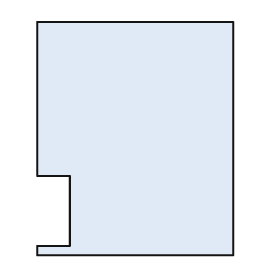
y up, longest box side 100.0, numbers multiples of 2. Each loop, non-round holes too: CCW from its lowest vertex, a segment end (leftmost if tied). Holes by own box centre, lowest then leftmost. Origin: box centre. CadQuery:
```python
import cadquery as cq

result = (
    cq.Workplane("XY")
    .moveTo(-42.0, -50.0)
    .lineTo(42.0, -50.0)
    .lineTo(42.0, 50.0)
    .lineTo(-42.0, 50.0)
    .lineTo(-42.0, -16.0)
    .lineTo(-28.0, -16.0)
    .lineTo(-28.0, -46.0)
    .lineTo(-42.0, -46.0)
    .close()
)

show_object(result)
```